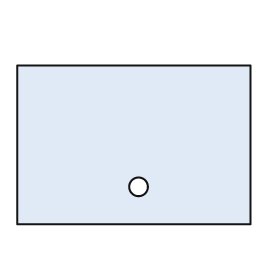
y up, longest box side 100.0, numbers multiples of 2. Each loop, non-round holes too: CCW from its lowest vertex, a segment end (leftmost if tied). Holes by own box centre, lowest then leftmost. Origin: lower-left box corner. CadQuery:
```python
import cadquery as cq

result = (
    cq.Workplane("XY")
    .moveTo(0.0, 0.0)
    .lineTo(100.0, 0.0)
    .lineTo(100.0, 68.0)
    .lineTo(0.0, 68.0)
    .close()
    .moveTo(52.0, 16.0)
    .circle(4.0)
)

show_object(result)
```